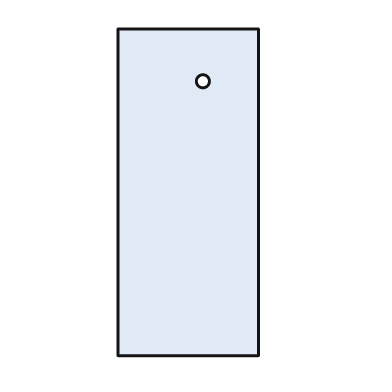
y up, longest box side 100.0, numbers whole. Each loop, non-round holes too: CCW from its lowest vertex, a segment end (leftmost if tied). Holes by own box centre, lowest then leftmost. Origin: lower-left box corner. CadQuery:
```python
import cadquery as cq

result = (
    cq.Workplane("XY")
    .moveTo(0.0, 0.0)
    .lineTo(43.0, 0.0)
    .lineTo(43.0, 100.0)
    .lineTo(0.0, 100.0)
    .close()
    .moveTo(26.0, 84.0)
    .circle(2.0)
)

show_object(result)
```